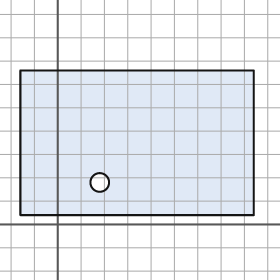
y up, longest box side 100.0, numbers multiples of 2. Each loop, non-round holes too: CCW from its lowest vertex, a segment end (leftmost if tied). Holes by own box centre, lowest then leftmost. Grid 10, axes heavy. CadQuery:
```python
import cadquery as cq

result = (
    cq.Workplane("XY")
    .moveTo(-16.0, 4.0)
    .lineTo(84.0, 4.0)
    .lineTo(84.0, 66.0)
    .lineTo(-16.0, 66.0)
    .close()
    .moveTo(18.0, 18.0)
    .circle(4.0)
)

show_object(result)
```